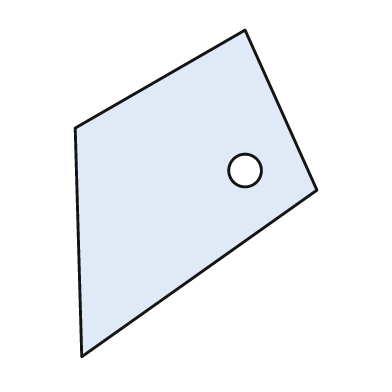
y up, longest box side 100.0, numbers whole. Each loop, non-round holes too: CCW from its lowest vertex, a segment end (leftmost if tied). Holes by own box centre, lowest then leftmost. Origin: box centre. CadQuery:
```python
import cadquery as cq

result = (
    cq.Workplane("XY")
    .moveTo(-35.0, -50.0)
    .lineTo(37.0, 1.0)
    .lineTo(15.0, 50.0)
    .lineTo(-37.0, 20.0)
    .close()
    .moveTo(15.0, 7.0)
    .circle(5.0)
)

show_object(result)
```